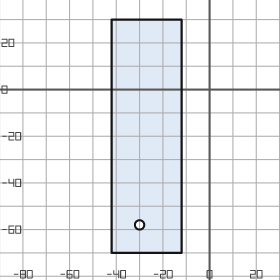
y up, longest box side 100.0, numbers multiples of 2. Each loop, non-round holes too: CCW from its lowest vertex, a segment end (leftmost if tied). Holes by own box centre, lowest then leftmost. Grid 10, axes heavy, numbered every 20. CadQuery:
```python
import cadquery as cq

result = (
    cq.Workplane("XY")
    .moveTo(-42.0, -70.0)
    .lineTo(-12.0, -70.0)
    .lineTo(-12.0, 30.0)
    .lineTo(-42.0, 30.0)
    .close()
    .moveTo(-30.0, -58.0)
    .circle(2.0)
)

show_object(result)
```